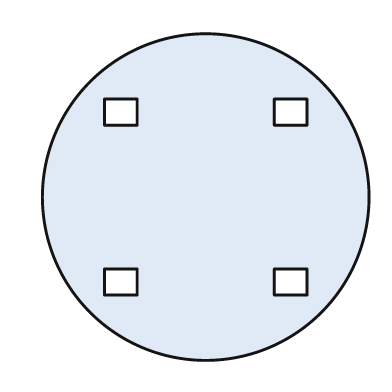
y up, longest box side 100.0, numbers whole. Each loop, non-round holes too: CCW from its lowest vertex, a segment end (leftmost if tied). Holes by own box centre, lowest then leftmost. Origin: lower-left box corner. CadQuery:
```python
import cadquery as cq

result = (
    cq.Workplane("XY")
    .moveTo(50.0, 50.0)
    .circle(50.0)
    .moveTo(19.0, 20.0)
    .lineTo(29.0, 20.0)
    .lineTo(29.0, 28.0)
    .lineTo(19.0, 28.0)
    .close()
    .moveTo(71.0, 20.0)
    .lineTo(81.0, 20.0)
    .lineTo(81.0, 28.0)
    .lineTo(71.0, 28.0)
    .close()
    .moveTo(19.0, 72.0)
    .lineTo(29.0, 72.0)
    .lineTo(29.0, 80.0)
    .lineTo(19.0, 80.0)
    .close()
    .moveTo(71.0, 72.0)
    .lineTo(81.0, 72.0)
    .lineTo(81.0, 80.0)
    .lineTo(71.0, 80.0)
    .close()
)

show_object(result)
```